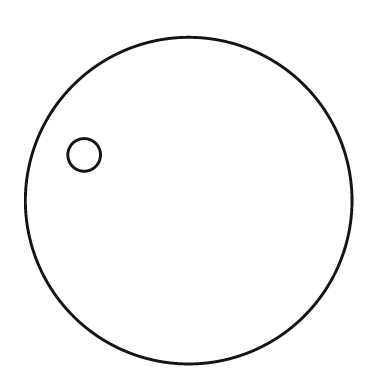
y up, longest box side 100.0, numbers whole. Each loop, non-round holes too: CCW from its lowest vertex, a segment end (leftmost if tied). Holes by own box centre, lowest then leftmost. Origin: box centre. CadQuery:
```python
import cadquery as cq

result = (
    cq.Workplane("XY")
    .moveTo(0.0, 0.0)
    .circle(50.0)
    .moveTo(-32.0, 14.0)
    .circle(5.0)
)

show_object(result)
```